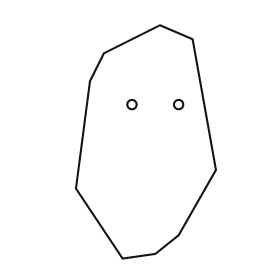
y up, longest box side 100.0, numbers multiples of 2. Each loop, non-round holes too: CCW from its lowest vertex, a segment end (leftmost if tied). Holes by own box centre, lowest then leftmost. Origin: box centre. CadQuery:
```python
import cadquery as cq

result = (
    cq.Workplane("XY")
    .moveTo(-10.0, -50.0)
    .lineTo(4.0, -48.0)
    .lineTo(14.0, -40.0)
    .lineTo(30.0, -12.0)
    .lineTo(20.0, 44.0)
    .lineTo(6.0, 50.0)
    .lineTo(-18.0, 38.0)
    .lineTo(-24.0, 26.0)
    .lineTo(-30.0, -20.0)
    .close()
    .moveTo(-6.0, 16.0)
    .circle(2.0)
    .moveTo(14.0, 16.0)
    .circle(2.0)
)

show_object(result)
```